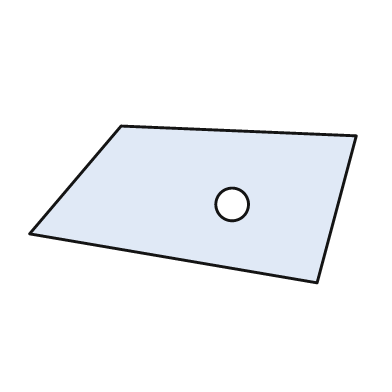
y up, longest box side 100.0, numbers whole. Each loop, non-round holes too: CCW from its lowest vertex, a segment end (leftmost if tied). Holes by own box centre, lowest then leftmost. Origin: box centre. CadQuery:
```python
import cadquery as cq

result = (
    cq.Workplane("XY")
    .moveTo(38.0, -24.0)
    .lineTo(50.0, 21.0)
    .lineTo(-22.0, 24.0)
    .lineTo(-50.0, -9.0)
    .close()
    .moveTo(12.0, 0.0)
    .circle(5.0)
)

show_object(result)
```